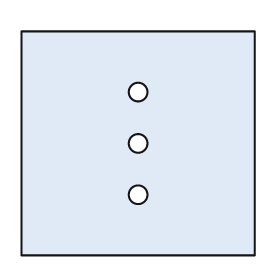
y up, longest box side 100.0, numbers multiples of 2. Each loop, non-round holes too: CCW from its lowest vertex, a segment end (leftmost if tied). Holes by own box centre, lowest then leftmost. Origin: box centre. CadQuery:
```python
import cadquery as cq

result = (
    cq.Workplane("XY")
    .moveTo(-50.0, -48.0)
    .lineTo(50.0, -48.0)
    .lineTo(50.0, 48.0)
    .lineTo(-50.0, 48.0)
    .close()
    .moveTo(0.0, -22.0)
    .circle(4.0)
    .moveTo(0.0, 0.0)
    .circle(4.0)
    .moveTo(0.0, 22.0)
    .circle(4.0)
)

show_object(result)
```